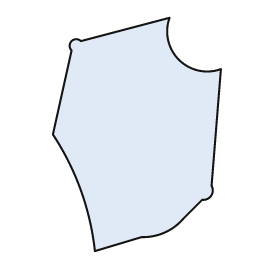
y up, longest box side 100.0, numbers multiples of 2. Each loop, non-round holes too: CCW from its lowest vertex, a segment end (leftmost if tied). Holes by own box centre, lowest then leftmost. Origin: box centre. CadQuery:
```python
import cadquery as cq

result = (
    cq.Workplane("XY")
    .moveTo(-18.0, -50.0)
    .lineTo(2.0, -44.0)
    .threePointArc((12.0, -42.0), (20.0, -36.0))
    .lineTo(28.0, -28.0)
    .threePointArc((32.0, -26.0), (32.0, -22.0))
    .lineTo(36.0, 28.0)
    .threePointArc((18.0, 32.0), (14.0, 50.0))
    .lineTo(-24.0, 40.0)
    .threePointArc((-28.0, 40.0), (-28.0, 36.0))
    .lineTo(-36.0, 0.0)
    .threePointArc((-24.0, -24.0), (-18.0, -50.0))
    .close()
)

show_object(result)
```